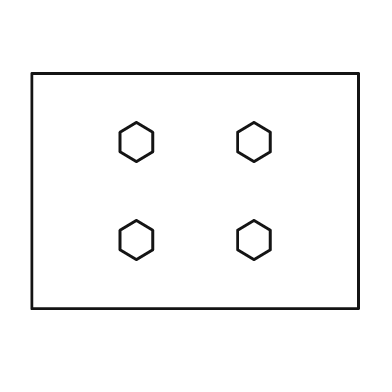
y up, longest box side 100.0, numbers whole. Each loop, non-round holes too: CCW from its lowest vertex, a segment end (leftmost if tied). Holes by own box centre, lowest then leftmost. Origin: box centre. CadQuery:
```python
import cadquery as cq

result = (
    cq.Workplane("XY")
    .moveTo(-50.0, -36.0)
    .lineTo(50.0, -36.0)
    .lineTo(50.0, 36.0)
    .lineTo(-50.0, 36.0)
    .close()
    .moveTo(-18.0, -21.0)
    .lineTo(-13.0, -18.0)
    .lineTo(-13.0, -12.0)
    .lineTo(-18.0, -9.0)
    .lineTo(-23.0, -12.0)
    .lineTo(-23.0, -18.0)
    .close()
    .moveTo(18.0, -21.0)
    .lineTo(23.0, -18.0)
    .lineTo(23.0, -12.0)
    .lineTo(18.0, -9.0)
    .lineTo(13.0, -12.0)
    .lineTo(13.0, -18.0)
    .close()
    .moveTo(-18.0, 9.0)
    .lineTo(-13.0, 12.0)
    .lineTo(-13.0, 18.0)
    .lineTo(-18.0, 21.0)
    .lineTo(-23.0, 18.0)
    .lineTo(-23.0, 12.0)
    .close()
    .moveTo(18.0, 9.0)
    .lineTo(23.0, 12.0)
    .lineTo(23.0, 18.0)
    .lineTo(18.0, 21.0)
    .lineTo(13.0, 18.0)
    .lineTo(13.0, 12.0)
    .close()
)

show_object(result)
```